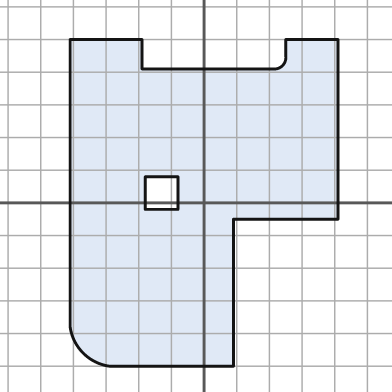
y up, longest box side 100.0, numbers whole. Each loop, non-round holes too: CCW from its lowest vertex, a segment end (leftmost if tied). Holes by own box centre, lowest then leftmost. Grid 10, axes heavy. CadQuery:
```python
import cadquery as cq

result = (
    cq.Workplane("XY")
    .moveTo(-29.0, -50.0)
    .lineTo(9.0, -50.0)
    .lineTo(9.0, -5.0)
    .lineTo(41.0, -5.0)
    .lineTo(41.0, 50.0)
    .lineTo(25.0, 50.0)
    .lineTo(25.0, 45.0)
    .threePointArc((24.0, 42.0), (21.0, 41.0))
    .lineTo(-19.0, 41.0)
    .lineTo(-19.0, 50.0)
    .lineTo(-41.0, 50.0)
    .lineTo(-41.0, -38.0)
    .threePointArc((-37.0, -46.0), (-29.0, -50.0))
    .close()
    .moveTo(-18.0, -2.0)
    .lineTo(-8.0, -2.0)
    .lineTo(-8.0, 8.0)
    .lineTo(-18.0, 8.0)
    .close()
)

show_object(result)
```